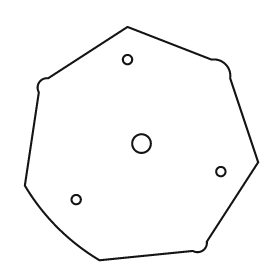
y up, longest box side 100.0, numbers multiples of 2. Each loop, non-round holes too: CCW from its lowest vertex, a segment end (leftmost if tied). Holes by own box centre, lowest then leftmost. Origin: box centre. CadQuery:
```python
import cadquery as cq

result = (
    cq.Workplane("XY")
    .moveTo(-18.0, -50.0)
    .lineTo(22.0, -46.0)
    .threePointArc((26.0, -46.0), (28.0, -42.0))
    .lineTo(50.0, -8.0)
    .lineTo(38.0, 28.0)
    .threePointArc((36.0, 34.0), (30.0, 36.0))
    .lineTo(-6.0, 50.0)
    .lineTo(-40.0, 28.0)
    .threePointArc((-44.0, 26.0), (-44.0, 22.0))
    .lineTo(-50.0, -18.0)
    .threePointArc((-36.0, -36.0), (-18.0, -50.0))
    .close()
    .moveTo(-28.0, -24.0)
    .circle(2.0)
    .moveTo(34.0, -12.0)
    .circle(2.0)
    .moveTo(0.0, 0.0)
    .circle(4.0)
    .moveTo(-6.0, 36.0)
    .circle(2.0)
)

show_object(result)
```